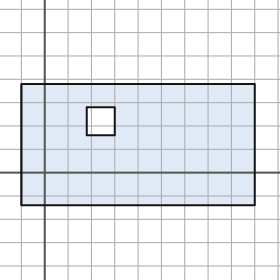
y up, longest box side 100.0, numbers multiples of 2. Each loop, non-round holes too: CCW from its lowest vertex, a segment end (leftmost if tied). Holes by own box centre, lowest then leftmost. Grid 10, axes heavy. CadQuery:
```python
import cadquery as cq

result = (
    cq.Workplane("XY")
    .moveTo(-10.0, -14.0)
    .lineTo(90.0, -14.0)
    .lineTo(90.0, 38.0)
    .lineTo(-10.0, 38.0)
    .close()
    .moveTo(18.0, 16.0)
    .lineTo(30.0, 16.0)
    .lineTo(30.0, 28.0)
    .lineTo(18.0, 28.0)
    .close()
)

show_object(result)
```